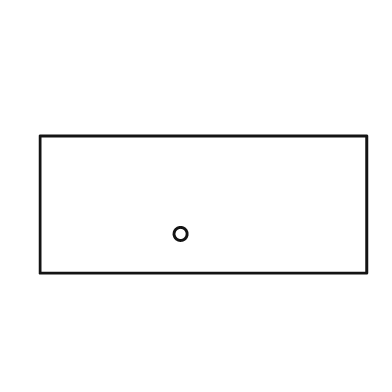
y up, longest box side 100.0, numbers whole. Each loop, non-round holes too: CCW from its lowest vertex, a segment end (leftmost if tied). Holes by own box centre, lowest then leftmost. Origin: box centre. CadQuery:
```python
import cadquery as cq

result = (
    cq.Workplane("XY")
    .moveTo(-50.0, -21.0)
    .lineTo(50.0, -21.0)
    .lineTo(50.0, 21.0)
    .lineTo(-50.0, 21.0)
    .close()
    .moveTo(-7.0, -9.0)
    .circle(2.0)
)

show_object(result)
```